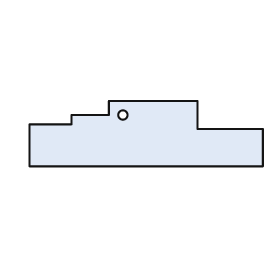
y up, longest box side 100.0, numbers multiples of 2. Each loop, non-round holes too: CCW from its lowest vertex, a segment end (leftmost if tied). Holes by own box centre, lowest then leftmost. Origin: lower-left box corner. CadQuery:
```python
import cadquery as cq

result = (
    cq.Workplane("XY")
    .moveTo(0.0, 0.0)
    .lineTo(100.0, 0.0)
    .lineTo(100.0, 16.0)
    .lineTo(72.0, 16.0)
    .lineTo(72.0, 28.0)
    .lineTo(34.0, 28.0)
    .lineTo(34.0, 22.0)
    .lineTo(18.0, 22.0)
    .lineTo(18.0, 18.0)
    .lineTo(0.0, 18.0)
    .close()
    .moveTo(40.0, 22.0)
    .circle(2.0)
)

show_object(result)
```